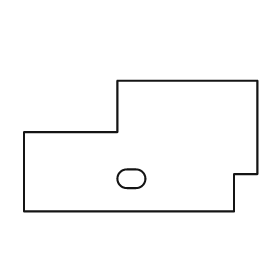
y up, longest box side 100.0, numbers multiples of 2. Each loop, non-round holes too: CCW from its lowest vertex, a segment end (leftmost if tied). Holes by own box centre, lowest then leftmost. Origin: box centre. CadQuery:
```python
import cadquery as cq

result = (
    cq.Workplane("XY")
    .moveTo(-50.0, -28.0)
    .lineTo(40.0, -28.0)
    .lineTo(40.0, -12.0)
    .lineTo(50.0, -12.0)
    .lineTo(50.0, 28.0)
    .lineTo(-10.0, 28.0)
    .lineTo(-10.0, 6.0)
    .lineTo(-50.0, 6.0)
    .close()
    .moveTo(-6.0, -18.0)
    .lineTo(-2.0, -18.0)
    .threePointArc((2.0, -14.0), (-2.0, -10.0))
    .lineTo(-6.0, -10.0)
    .threePointArc((-10.0, -14.0), (-6.0, -18.0))
    .close()
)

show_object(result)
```